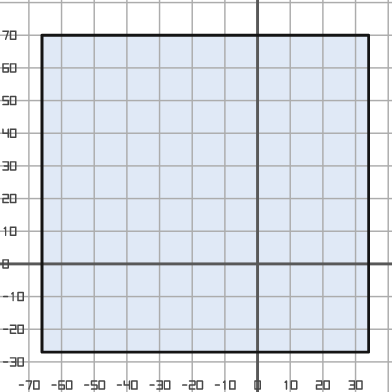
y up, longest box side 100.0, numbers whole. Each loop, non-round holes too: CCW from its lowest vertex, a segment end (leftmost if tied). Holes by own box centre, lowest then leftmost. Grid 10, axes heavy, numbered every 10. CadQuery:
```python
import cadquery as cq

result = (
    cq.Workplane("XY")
    .moveTo(-66.0, -27.0)
    .lineTo(34.0, -27.0)
    .lineTo(34.0, 70.0)
    .lineTo(-66.0, 70.0)
    .close()
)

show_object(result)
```